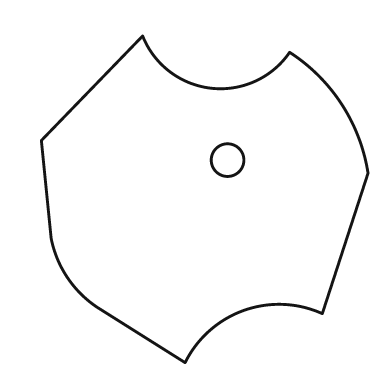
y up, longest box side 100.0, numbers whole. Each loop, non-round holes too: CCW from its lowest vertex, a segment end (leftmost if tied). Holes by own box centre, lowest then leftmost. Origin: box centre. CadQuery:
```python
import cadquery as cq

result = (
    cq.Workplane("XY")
    .moveTo(-6.0, -50.0)
    .threePointArc((12.0, -34.0), (36.0, -35.0))
    .lineTo(50.0, 8.0)
    .threePointArc((42.0, 29.0), (26.0, 45.0))
    .threePointArc((2.0, 34.0), (-19.0, 50.0))
    .lineTo(-50.0, 18.0)
    .lineTo(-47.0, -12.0)
    .threePointArc((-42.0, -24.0), (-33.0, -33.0))
    .close()
    .moveTo(7.0, 12.0)
    .circle(5.0)
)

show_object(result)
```